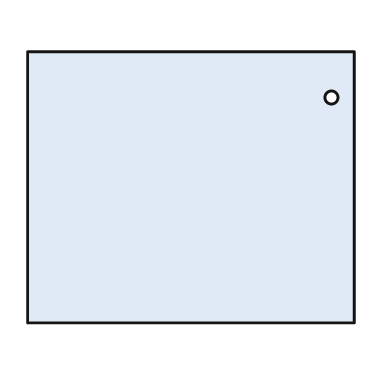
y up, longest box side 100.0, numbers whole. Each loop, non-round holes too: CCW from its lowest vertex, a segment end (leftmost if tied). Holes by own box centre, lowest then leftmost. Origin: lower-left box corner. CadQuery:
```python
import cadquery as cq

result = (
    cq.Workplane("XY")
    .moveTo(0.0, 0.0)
    .lineTo(100.0, 0.0)
    .lineTo(100.0, 83.0)
    .lineTo(0.0, 83.0)
    .close()
    .moveTo(93.0, 69.0)
    .circle(2.0)
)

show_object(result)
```